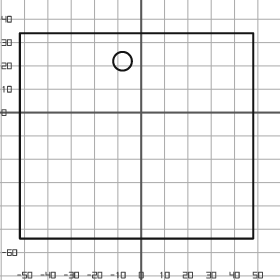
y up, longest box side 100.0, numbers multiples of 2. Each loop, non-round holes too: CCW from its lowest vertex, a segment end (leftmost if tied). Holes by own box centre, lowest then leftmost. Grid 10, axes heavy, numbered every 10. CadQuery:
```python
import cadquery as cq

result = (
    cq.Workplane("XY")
    .moveTo(-52.0, -54.0)
    .lineTo(48.0, -54.0)
    .lineTo(48.0, 34.0)
    .lineTo(-52.0, 34.0)
    .close()
    .moveTo(-8.0, 22.0)
    .circle(4.0)
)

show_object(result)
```